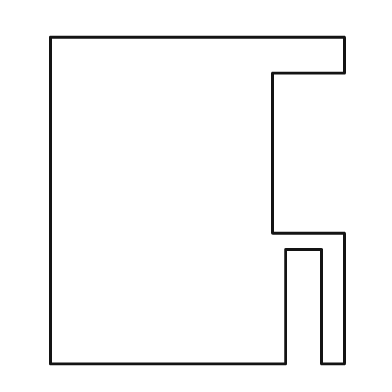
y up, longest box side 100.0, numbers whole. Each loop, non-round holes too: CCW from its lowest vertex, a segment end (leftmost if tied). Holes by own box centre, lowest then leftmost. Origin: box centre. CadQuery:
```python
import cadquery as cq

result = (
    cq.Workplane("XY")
    .moveTo(-45.0, -50.0)
    .lineTo(27.0, -50.0)
    .lineTo(27.0, -15.0)
    .lineTo(38.0, -15.0)
    .lineTo(38.0, -50.0)
    .lineTo(45.0, -50.0)
    .lineTo(45.0, -10.0)
    .lineTo(23.0, -10.0)
    .lineTo(23.0, 39.0)
    .lineTo(45.0, 39.0)
    .lineTo(45.0, 50.0)
    .lineTo(-45.0, 50.0)
    .close()
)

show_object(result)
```